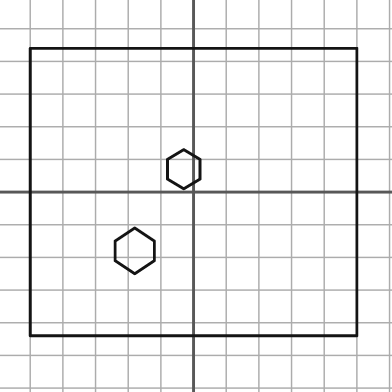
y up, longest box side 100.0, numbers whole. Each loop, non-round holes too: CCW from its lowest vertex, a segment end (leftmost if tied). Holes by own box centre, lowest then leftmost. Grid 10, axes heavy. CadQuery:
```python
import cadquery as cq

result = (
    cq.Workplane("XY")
    .moveTo(-50.0, -44.0)
    .lineTo(50.0, -44.0)
    .lineTo(50.0, 44.0)
    .lineTo(-50.0, 44.0)
    .close()
    .moveTo(-18.0, -25.0)
    .lineTo(-12.0, -21.0)
    .lineTo(-12.0, -15.0)
    .lineTo(-18.0, -11.0)
    .lineTo(-24.0, -15.0)
    .lineTo(-24.0, -21.0)
    .close()
    .moveTo(-3.0, 1.0)
    .lineTo(2.0, 4.0)
    .lineTo(2.0, 10.0)
    .lineTo(-3.0, 13.0)
    .lineTo(-8.0, 10.0)
    .lineTo(-8.0, 4.0)
    .close()
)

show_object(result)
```